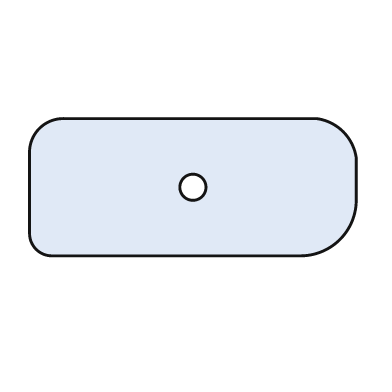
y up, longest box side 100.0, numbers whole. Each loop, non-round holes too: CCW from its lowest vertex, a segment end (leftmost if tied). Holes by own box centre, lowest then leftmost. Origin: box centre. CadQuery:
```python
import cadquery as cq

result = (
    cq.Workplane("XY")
    .moveTo(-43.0, -21.0)
    .lineTo(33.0, -21.0)
    .threePointArc((45.0, -16.0), (50.0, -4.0))
    .lineTo(50.0, 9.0)
    .threePointArc((46.0, 17.0), (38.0, 21.0))
    .lineTo(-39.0, 21.0)
    .threePointArc((-47.0, 18.0), (-50.0, 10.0))
    .lineTo(-50.0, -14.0)
    .threePointArc((-48.0, -19.0), (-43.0, -21.0))
    .close()
    .moveTo(0.0, 0.0)
    .circle(4.0)
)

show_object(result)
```